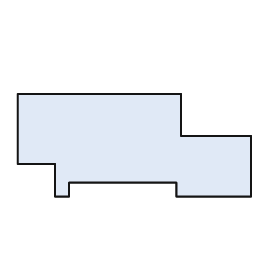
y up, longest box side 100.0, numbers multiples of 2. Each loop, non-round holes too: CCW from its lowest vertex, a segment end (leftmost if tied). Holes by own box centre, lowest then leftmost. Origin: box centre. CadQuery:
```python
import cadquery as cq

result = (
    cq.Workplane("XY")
    .moveTo(-34.0, -22.0)
    .lineTo(-28.0, -22.0)
    .lineTo(-28.0, -16.0)
    .lineTo(18.0, -16.0)
    .lineTo(18.0, -22.0)
    .lineTo(50.0, -22.0)
    .lineTo(50.0, 4.0)
    .lineTo(20.0, 4.0)
    .lineTo(20.0, 22.0)
    .lineTo(-50.0, 22.0)
    .lineTo(-50.0, -8.0)
    .lineTo(-34.0, -8.0)
    .close()
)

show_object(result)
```